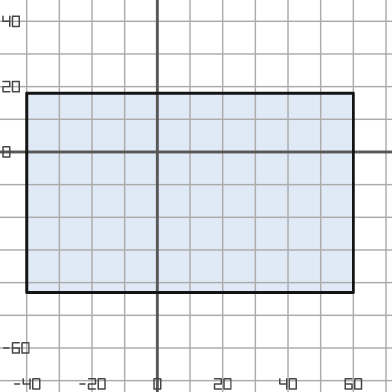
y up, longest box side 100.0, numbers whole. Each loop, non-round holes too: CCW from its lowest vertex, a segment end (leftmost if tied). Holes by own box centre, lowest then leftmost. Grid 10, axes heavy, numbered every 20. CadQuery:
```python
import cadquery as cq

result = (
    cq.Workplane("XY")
    .moveTo(-40.0, -43.0)
    .lineTo(60.0, -43.0)
    .lineTo(60.0, 18.0)
    .lineTo(-40.0, 18.0)
    .close()
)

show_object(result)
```